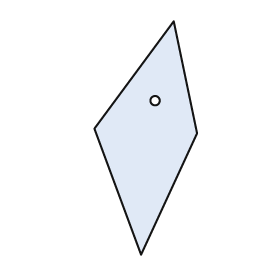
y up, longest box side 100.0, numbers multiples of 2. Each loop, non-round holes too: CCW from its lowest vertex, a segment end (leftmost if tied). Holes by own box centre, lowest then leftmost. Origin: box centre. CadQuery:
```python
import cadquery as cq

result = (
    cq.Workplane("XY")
    .moveTo(-2.0, -50.0)
    .lineTo(22.0, 2.0)
    .lineTo(12.0, 50.0)
    .lineTo(-22.0, 4.0)
    .close()
    .moveTo(4.0, 16.0)
    .circle(2.0)
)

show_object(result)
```